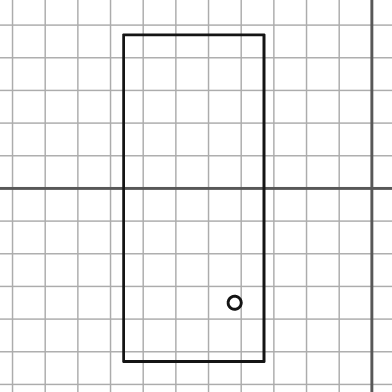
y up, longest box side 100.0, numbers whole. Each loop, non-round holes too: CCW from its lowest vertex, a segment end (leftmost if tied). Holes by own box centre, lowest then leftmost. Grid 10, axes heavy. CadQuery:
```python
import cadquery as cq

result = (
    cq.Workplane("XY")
    .moveTo(-76.0, -53.0)
    .lineTo(-33.0, -53.0)
    .lineTo(-33.0, 47.0)
    .lineTo(-76.0, 47.0)
    .close()
    .moveTo(-42.0, -35.0)
    .circle(2.0)
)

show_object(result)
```